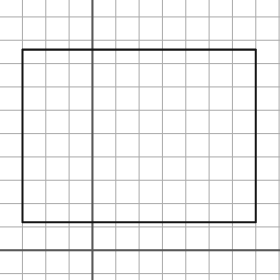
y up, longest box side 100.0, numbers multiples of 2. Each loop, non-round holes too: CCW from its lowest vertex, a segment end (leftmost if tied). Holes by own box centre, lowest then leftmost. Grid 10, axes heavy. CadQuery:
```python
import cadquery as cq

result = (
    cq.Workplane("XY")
    .moveTo(-30.0, 12.0)
    .lineTo(70.0, 12.0)
    .lineTo(70.0, 86.0)
    .lineTo(-30.0, 86.0)
    .close()
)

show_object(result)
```